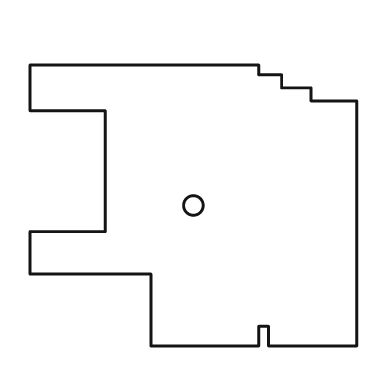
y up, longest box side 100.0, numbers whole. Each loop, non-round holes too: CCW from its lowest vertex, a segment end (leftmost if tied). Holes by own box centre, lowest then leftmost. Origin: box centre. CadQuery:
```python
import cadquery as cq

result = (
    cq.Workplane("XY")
    .moveTo(-13.0, -43.0)
    .lineTo(20.0, -43.0)
    .lineTo(20.0, -37.0)
    .lineTo(23.0, -37.0)
    .lineTo(23.0, -43.0)
    .lineTo(50.0, -43.0)
    .lineTo(50.0, 32.0)
    .lineTo(36.0, 32.0)
    .lineTo(36.0, 36.0)
    .lineTo(27.0, 36.0)
    .lineTo(27.0, 40.0)
    .lineTo(20.0, 40.0)
    .lineTo(20.0, 43.0)
    .lineTo(-50.0, 43.0)
    .lineTo(-50.0, 29.0)
    .lineTo(-27.0, 29.0)
    .lineTo(-27.0, -8.0)
    .lineTo(-50.0, -8.0)
    .lineTo(-50.0, -21.0)
    .lineTo(-13.0, -21.0)
    .close()
    .moveTo(0.0, 0.0)
    .circle(3.0)
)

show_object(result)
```